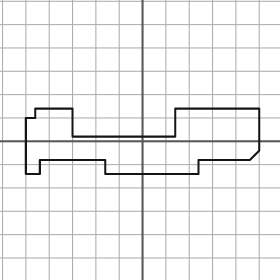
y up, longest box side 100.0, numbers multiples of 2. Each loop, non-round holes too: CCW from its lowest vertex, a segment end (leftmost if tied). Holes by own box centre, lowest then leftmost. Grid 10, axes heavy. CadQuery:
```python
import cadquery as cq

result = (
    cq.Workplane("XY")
    .moveTo(-50.0, -14.0)
    .lineTo(-44.0, -14.0)
    .lineTo(-44.0, -8.0)
    .lineTo(-16.0, -8.0)
    .lineTo(-16.0, -14.0)
    .lineTo(24.0, -14.0)
    .lineTo(24.0, -8.0)
    .lineTo(46.0, -8.0)
    .lineTo(50.0, -4.0)
    .lineTo(50.0, 14.0)
    .lineTo(14.0, 14.0)
    .lineTo(14.0, 2.0)
    .lineTo(-30.0, 2.0)
    .lineTo(-30.0, 14.0)
    .lineTo(-46.0, 14.0)
    .lineTo(-46.0, 10.0)
    .lineTo(-50.0, 10.0)
    .close()
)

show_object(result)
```